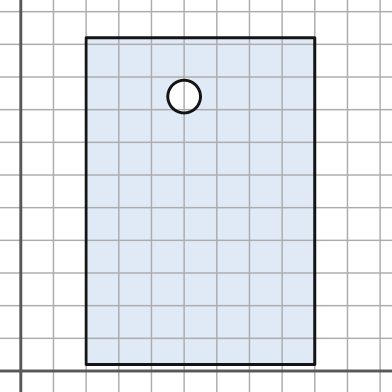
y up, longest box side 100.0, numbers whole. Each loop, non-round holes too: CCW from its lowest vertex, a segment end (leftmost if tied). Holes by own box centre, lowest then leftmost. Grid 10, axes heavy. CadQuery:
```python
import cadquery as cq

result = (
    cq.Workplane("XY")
    .moveTo(20.0, 2.0)
    .lineTo(90.0, 2.0)
    .lineTo(90.0, 102.0)
    .lineTo(20.0, 102.0)
    .close()
    .moveTo(50.0, 84.0)
    .circle(5.0)
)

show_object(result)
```